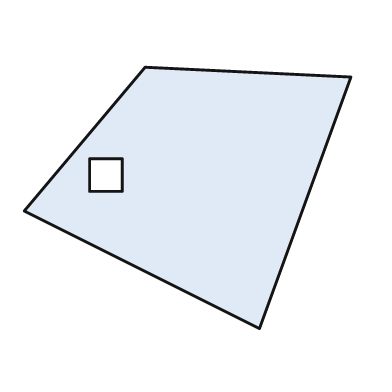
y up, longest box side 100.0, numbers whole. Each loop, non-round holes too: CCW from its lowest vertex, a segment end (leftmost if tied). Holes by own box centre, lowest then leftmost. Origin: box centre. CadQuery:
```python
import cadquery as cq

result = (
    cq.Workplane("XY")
    .moveTo(22.0, -40.0)
    .lineTo(50.0, 37.0)
    .lineTo(-13.0, 40.0)
    .lineTo(-50.0, -4.0)
    .close()
    .moveTo(-30.0, 2.0)
    .lineTo(-20.0, 2.0)
    .lineTo(-20.0, 12.0)
    .lineTo(-30.0, 12.0)
    .close()
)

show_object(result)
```